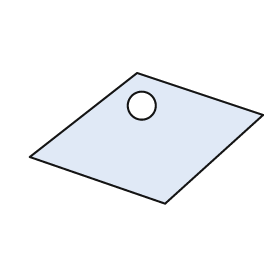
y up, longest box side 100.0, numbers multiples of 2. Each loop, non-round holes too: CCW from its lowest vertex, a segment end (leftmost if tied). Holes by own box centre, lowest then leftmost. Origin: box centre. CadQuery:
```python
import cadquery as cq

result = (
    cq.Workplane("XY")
    .moveTo(8.0, -28.0)
    .lineTo(50.0, 10.0)
    .lineTo(-4.0, 28.0)
    .lineTo(-50.0, -8.0)
    .close()
    .moveTo(-2.0, 14.0)
    .circle(6.0)
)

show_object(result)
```